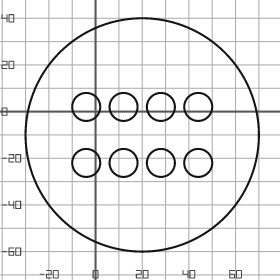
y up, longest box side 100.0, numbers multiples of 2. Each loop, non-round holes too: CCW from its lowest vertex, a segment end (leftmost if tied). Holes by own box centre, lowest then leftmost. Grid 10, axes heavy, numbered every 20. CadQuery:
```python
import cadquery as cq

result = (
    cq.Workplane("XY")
    .moveTo(20.0, -10.0)
    .circle(50.0)
    .moveTo(-4.0, -22.0)
    .circle(6.0)
    .moveTo(12.0, -22.0)
    .circle(6.0)
    .moveTo(28.0, -22.0)
    .circle(6.0)
    .moveTo(44.0, -22.0)
    .circle(6.0)
    .moveTo(-4.0, 2.0)
    .circle(6.0)
    .moveTo(12.0, 2.0)
    .circle(6.0)
    .moveTo(28.0, 2.0)
    .circle(6.0)
    .moveTo(44.0, 2.0)
    .circle(6.0)
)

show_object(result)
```